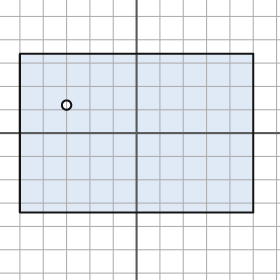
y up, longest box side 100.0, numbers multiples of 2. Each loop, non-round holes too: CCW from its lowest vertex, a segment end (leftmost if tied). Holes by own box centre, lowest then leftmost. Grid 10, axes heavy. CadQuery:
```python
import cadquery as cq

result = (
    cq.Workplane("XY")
    .moveTo(-50.0, -34.0)
    .lineTo(50.0, -34.0)
    .lineTo(50.0, 34.0)
    .lineTo(-50.0, 34.0)
    .close()
    .moveTo(-30.0, 12.0)
    .circle(2.0)
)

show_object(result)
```